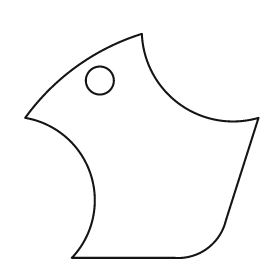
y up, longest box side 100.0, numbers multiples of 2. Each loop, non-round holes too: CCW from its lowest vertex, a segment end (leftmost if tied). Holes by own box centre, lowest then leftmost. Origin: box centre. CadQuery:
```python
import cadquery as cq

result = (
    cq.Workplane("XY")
    .moveTo(-30.0, -48.0)
    .lineTo(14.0, -48.0)
    .threePointArc((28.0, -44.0), (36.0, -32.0))
    .lineTo(50.0, 12.0)
    .threePointArc((16.0, 18.0), (0.0, 48.0))
    .threePointArc((-28.0, 34.0), (-50.0, 12.0))
    .threePointArc((-22.0, -12.0), (-30.0, -48.0))
    .close()
    .moveTo(-18.0, 28.0)
    .circle(6.0)
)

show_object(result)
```